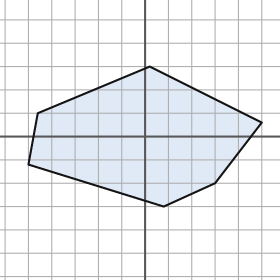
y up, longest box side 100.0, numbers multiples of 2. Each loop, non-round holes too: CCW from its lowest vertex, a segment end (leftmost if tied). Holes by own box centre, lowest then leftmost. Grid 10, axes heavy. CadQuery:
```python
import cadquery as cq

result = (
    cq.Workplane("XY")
    .moveTo(8.0, -30.0)
    .lineTo(30.0, -20.0)
    .lineTo(50.0, 6.0)
    .lineTo(2.0, 30.0)
    .lineTo(-46.0, 10.0)
    .lineTo(-50.0, -12.0)
    .close()
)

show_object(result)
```